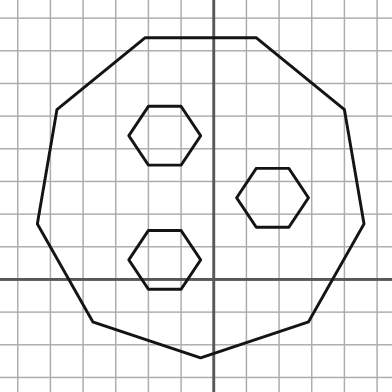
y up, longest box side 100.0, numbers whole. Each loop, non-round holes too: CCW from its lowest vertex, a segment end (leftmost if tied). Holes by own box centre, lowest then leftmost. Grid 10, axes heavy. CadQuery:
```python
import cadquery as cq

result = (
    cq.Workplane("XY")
    .moveTo(-4.0, -24.0)
    .lineTo(29.0, -13.0)
    .lineTo(46.0, 17.0)
    .lineTo(40.0, 52.0)
    .lineTo(13.0, 74.0)
    .lineTo(-21.0, 74.0)
    .lineTo(-48.0, 52.0)
    .lineTo(-54.0, 17.0)
    .lineTo(-37.0, -13.0)
    .close()
    .moveTo(-20.0, -3.0)
    .lineTo(-10.0, -3.0)
    .lineTo(-4.0, 6.0)
    .lineTo(-10.0, 15.0)
    .lineTo(-20.0, 15.0)
    .lineTo(-26.0, 6.0)
    .close()
    .moveTo(13.0, 16.0)
    .lineTo(23.0, 16.0)
    .lineTo(29.0, 25.0)
    .lineTo(23.0, 34.0)
    .lineTo(13.0, 34.0)
    .lineTo(7.0, 25.0)
    .close()
    .moveTo(-20.0, 35.0)
    .lineTo(-10.0, 35.0)
    .lineTo(-4.0, 44.0)
    .lineTo(-10.0, 53.0)
    .lineTo(-20.0, 53.0)
    .lineTo(-26.0, 44.0)
    .close()
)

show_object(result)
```